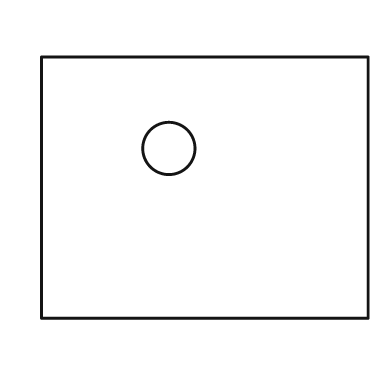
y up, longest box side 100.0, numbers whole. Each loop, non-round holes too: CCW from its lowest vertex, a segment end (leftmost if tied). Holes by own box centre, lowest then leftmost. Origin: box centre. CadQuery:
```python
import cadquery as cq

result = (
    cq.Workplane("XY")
    .moveTo(-50.0, -40.0)
    .lineTo(50.0, -40.0)
    .lineTo(50.0, 40.0)
    .lineTo(-50.0, 40.0)
    .close()
    .moveTo(-11.0, 12.0)
    .circle(8.0)
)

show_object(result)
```